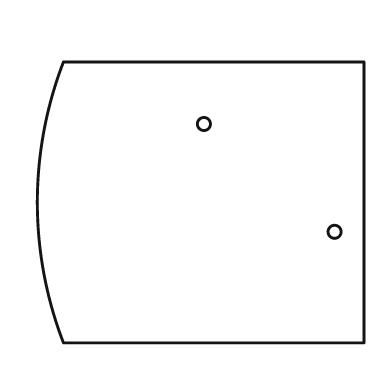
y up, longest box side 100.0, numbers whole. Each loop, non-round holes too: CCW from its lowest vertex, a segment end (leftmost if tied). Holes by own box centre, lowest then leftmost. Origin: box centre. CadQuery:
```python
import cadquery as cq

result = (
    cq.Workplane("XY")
    .moveTo(-42.0, -43.0)
    .lineTo(50.0, -43.0)
    .lineTo(50.0, 43.0)
    .lineTo(-42.0, 43.0)
    .threePointArc((-50.0, 0.0), (-42.0, -43.0))
    .close()
    .moveTo(41.0, -9.0)
    .circle(2.0)
    .moveTo(1.0, 24.0)
    .circle(2.0)
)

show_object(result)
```